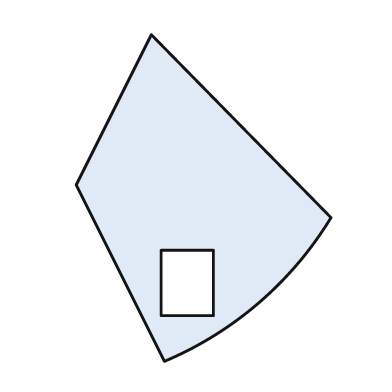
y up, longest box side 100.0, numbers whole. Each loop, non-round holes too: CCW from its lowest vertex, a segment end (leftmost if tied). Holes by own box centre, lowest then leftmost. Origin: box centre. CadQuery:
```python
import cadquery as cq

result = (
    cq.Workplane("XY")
    .moveTo(-12.0, -50.0)
    .threePointArc((17.0, -32.0), (39.0, -6.0))
    .lineTo(-16.0, 50.0)
    .lineTo(-39.0, 4.0)
    .close()
    .moveTo(-13.0, -36.0)
    .lineTo(3.0, -36.0)
    .lineTo(3.0, -16.0)
    .lineTo(-13.0, -16.0)
    .close()
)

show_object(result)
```